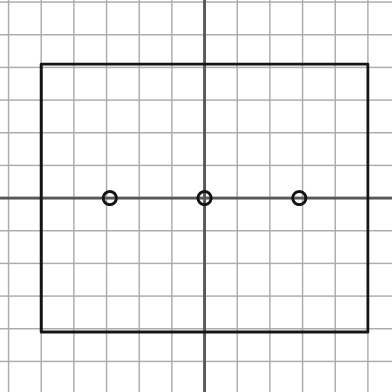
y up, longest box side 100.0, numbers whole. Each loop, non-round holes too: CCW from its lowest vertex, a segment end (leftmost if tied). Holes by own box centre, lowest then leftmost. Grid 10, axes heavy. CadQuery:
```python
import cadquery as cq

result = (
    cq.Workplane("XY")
    .moveTo(-50.0, -41.0)
    .lineTo(50.0, -41.0)
    .lineTo(50.0, 41.0)
    .lineTo(-50.0, 41.0)
    .close()
    .moveTo(-29.0, 0.0)
    .circle(2.0)
    .moveTo(0.0, 0.0)
    .circle(2.0)
    .moveTo(29.0, 0.0)
    .circle(2.0)
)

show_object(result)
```